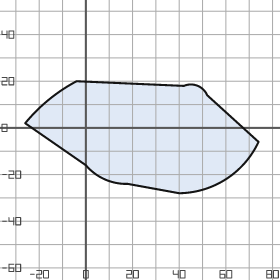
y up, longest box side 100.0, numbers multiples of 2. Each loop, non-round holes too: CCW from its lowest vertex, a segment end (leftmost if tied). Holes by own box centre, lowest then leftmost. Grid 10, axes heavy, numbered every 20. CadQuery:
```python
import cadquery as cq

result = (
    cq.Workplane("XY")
    .moveTo(40.0, -28.0)
    .threePointArc((60.0, -22.0), (74.0, -6.0))
    .lineTo(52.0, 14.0)
    .threePointArc((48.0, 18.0), (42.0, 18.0))
    .lineTo(-4.0, 20.0)
    .threePointArc((-16.0, 12.0), (-26.0, 2.0))
    .lineTo(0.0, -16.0)
    .threePointArc((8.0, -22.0), (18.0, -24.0))
    .close()
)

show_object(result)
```